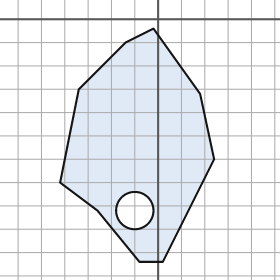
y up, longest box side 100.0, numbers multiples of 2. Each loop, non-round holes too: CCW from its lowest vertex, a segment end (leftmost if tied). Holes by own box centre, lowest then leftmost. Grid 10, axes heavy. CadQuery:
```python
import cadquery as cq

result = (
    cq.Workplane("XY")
    .moveTo(-8.0, -104.0)
    .lineTo(2.0, -104.0)
    .lineTo(24.0, -60.0)
    .lineTo(18.0, -32.0)
    .lineTo(-2.0, -4.0)
    .lineTo(-14.0, -10.0)
    .lineTo(-34.0, -30.0)
    .lineTo(-42.0, -70.0)
    .lineTo(-26.0, -82.0)
    .close()
    .moveTo(-10.0, -82.0)
    .circle(8.0)
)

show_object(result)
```